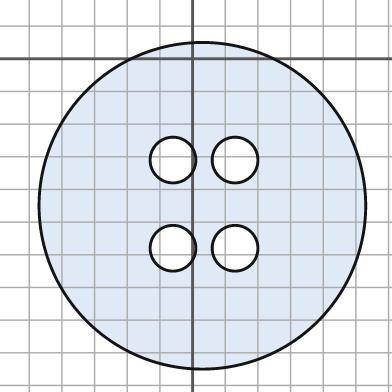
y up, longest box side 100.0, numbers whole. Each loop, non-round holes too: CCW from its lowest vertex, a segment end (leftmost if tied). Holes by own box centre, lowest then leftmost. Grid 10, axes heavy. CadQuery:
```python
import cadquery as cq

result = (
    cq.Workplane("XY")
    .moveTo(3.0, -45.0)
    .circle(50.0)
    .moveTo(-6.0, -58.0)
    .circle(7.0)
    .moveTo(13.0, -58.0)
    .circle(7.0)
    .moveTo(-6.0, -31.0)
    .circle(7.0)
    .moveTo(13.0, -31.0)
    .circle(7.0)
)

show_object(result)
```